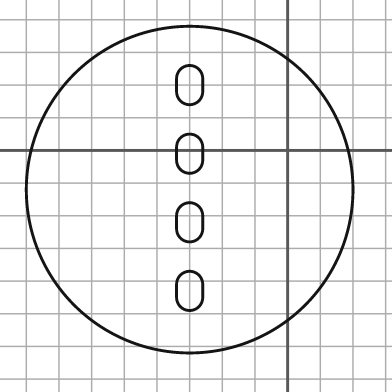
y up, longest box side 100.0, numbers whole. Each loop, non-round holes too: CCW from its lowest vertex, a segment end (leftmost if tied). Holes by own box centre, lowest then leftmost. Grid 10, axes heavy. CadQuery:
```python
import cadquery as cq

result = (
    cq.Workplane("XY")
    .moveTo(-30.0, -12.0)
    .circle(50.0)
    .moveTo(-34.0, -45.0)
    .threePointArc((-30.0, -49.0), (-26.0, -45.0))
    .lineTo(-26.0, -41.0)
    .threePointArc((-30.0, -37.0), (-34.0, -41.0))
    .close()
    .moveTo(-34.0, -24.0)
    .threePointArc((-30.0, -28.0), (-26.0, -24.0))
    .lineTo(-26.0, -20.0)
    .threePointArc((-30.0, -16.0), (-34.0, -20.0))
    .close()
    .moveTo(-34.0, -3.0)
    .threePointArc((-30.0, -7.0), (-26.0, -3.0))
    .lineTo(-26.0, 1.0)
    .threePointArc((-30.0, 5.0), (-34.0, 1.0))
    .close()
    .moveTo(-34.0, 18.0)
    .threePointArc((-30.0, 14.0), (-26.0, 18.0))
    .lineTo(-26.0, 22.0)
    .threePointArc((-30.0, 26.0), (-34.0, 22.0))
    .close()
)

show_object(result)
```